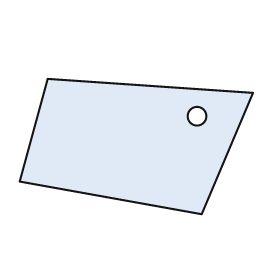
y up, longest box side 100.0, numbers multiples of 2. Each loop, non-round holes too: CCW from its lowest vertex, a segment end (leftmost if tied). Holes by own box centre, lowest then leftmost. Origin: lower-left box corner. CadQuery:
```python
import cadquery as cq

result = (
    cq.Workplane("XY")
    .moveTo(78.0, 0.0)
    .lineTo(100.0, 52.0)
    .lineTo(12.0, 58.0)
    .lineTo(0.0, 14.0)
    .close()
    .moveTo(76.0, 42.0)
    .circle(4.0)
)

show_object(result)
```